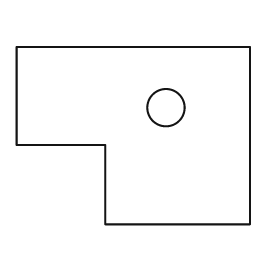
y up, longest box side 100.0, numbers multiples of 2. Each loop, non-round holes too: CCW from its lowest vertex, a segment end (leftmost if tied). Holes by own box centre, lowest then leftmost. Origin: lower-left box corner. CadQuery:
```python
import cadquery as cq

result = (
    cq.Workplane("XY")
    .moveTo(38.0, 0.0)
    .lineTo(100.0, 0.0)
    .lineTo(100.0, 76.0)
    .lineTo(0.0, 76.0)
    .lineTo(0.0, 34.0)
    .lineTo(38.0, 34.0)
    .close()
    .moveTo(64.0, 50.0)
    .circle(8.0)
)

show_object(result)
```